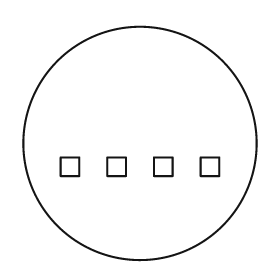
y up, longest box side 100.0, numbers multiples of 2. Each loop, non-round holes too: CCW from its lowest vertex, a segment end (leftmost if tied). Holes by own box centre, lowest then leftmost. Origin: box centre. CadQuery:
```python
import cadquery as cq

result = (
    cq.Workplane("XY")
    .moveTo(0.0, 0.0)
    .circle(50.0)
    .moveTo(-34.0, -14.0)
    .lineTo(-26.0, -14.0)
    .lineTo(-26.0, -6.0)
    .lineTo(-34.0, -6.0)
    .close()
    .moveTo(-14.0, -14.0)
    .lineTo(-6.0, -14.0)
    .lineTo(-6.0, -6.0)
    .lineTo(-14.0, -6.0)
    .close()
    .moveTo(6.0, -14.0)
    .lineTo(14.0, -14.0)
    .lineTo(14.0, -6.0)
    .lineTo(6.0, -6.0)
    .close()
    .moveTo(26.0, -14.0)
    .lineTo(34.0, -14.0)
    .lineTo(34.0, -6.0)
    .lineTo(26.0, -6.0)
    .close()
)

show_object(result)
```